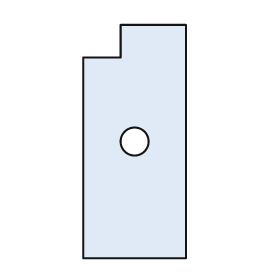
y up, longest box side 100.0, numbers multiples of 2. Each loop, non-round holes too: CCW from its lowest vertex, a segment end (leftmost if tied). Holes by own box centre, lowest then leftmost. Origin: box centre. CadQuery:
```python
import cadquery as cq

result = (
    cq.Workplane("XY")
    .moveTo(-22.0, -50.0)
    .lineTo(22.0, -50.0)
    .lineTo(22.0, 50.0)
    .lineTo(-6.0, 50.0)
    .lineTo(-6.0, 36.0)
    .lineTo(-22.0, 36.0)
    .close()
    .moveTo(0.0, 0.0)
    .circle(6.0)
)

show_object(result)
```